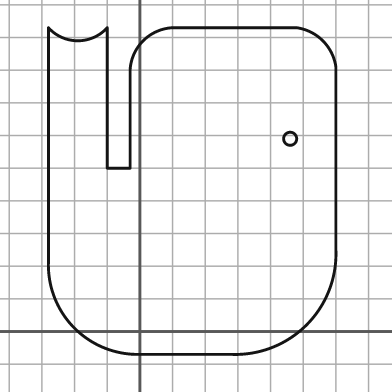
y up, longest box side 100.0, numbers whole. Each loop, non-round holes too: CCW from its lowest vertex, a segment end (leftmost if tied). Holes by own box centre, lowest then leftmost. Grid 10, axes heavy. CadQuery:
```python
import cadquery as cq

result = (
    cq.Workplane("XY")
    .moveTo(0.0, -7.0)
    .lineTo(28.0, -7.0)
    .threePointArc((51.0, 2.0), (60.0, 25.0))
    .lineTo(60.0, 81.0)
    .threePointArc((56.0, 89.0), (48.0, 93.0))
    .lineTo(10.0, 93.0)
    .threePointArc((1.0, 89.0), (-3.0, 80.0))
    .lineTo(-3.0, 50.0)
    .lineTo(-10.0, 50.0)
    .lineTo(-10.0, 93.0)
    .threePointArc((-19.0, 89.0), (-28.0, 93.0))
    .lineTo(-28.0, 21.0)
    .threePointArc((-20.0, 1.0), (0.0, -7.0))
    .close()
    .moveTo(46.0, 59.0)
    .circle(2.0)
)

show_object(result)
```